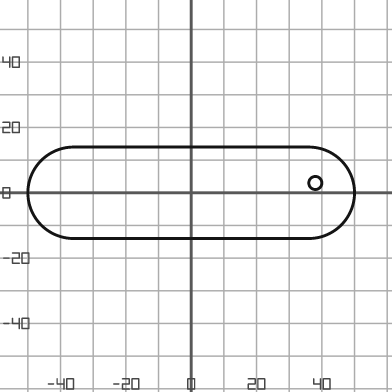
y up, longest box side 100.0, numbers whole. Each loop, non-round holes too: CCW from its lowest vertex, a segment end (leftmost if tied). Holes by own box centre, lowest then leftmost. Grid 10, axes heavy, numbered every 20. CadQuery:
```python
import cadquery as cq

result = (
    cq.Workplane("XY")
    .moveTo(-36.0, -14.0)
    .lineTo(36.0, -14.0)
    .threePointArc((50.0, 0.0), (36.0, 14.0))
    .lineTo(-36.0, 14.0)
    .threePointArc((-50.0, 0.0), (-36.0, -14.0))
    .close()
    .moveTo(38.0, 3.0)
    .circle(2.0)
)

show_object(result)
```